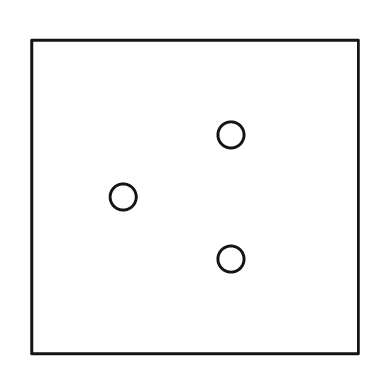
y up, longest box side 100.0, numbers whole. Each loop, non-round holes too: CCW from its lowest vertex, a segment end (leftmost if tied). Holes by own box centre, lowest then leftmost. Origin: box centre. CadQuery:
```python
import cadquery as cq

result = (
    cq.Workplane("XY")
    .moveTo(-50.0, -48.0)
    .lineTo(50.0, -48.0)
    .lineTo(50.0, 48.0)
    .lineTo(-50.0, 48.0)
    .close()
    .moveTo(11.0, -19.0)
    .circle(4.0)
    .moveTo(-22.0, 0.0)
    .circle(4.0)
    .moveTo(11.0, 19.0)
    .circle(4.0)
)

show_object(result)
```